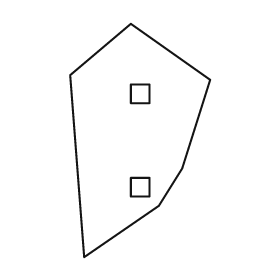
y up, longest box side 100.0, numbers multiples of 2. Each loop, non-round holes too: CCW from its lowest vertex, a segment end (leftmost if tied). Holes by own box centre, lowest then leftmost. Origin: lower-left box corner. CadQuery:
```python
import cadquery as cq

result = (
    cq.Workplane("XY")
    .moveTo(6.0, 0.0)
    .lineTo(38.0, 22.0)
    .lineTo(48.0, 38.0)
    .lineTo(60.0, 76.0)
    .lineTo(26.0, 100.0)
    .lineTo(0.0, 78.0)
    .close()
    .moveTo(26.0, 26.0)
    .lineTo(34.0, 26.0)
    .lineTo(34.0, 34.0)
    .lineTo(26.0, 34.0)
    .close()
    .moveTo(26.0, 66.0)
    .lineTo(34.0, 66.0)
    .lineTo(34.0, 74.0)
    .lineTo(26.0, 74.0)
    .close()
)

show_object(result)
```